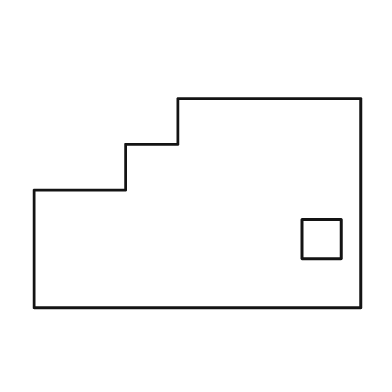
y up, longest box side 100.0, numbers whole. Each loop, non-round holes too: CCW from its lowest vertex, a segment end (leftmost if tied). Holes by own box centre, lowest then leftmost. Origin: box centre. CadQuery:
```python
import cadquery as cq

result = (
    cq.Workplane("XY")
    .moveTo(-50.0, -32.0)
    .lineTo(50.0, -32.0)
    .lineTo(50.0, 32.0)
    .lineTo(-6.0, 32.0)
    .lineTo(-6.0, 18.0)
    .lineTo(-22.0, 18.0)
    .lineTo(-22.0, 4.0)
    .lineTo(-50.0, 4.0)
    .close()
    .moveTo(32.0, -17.0)
    .lineTo(44.0, -17.0)
    .lineTo(44.0, -5.0)
    .lineTo(32.0, -5.0)
    .close()
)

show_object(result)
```